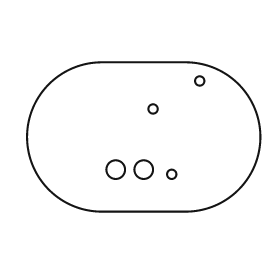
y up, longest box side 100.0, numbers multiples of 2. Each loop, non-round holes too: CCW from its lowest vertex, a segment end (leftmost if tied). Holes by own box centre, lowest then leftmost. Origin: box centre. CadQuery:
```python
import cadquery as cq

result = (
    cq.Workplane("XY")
    .moveTo(-18.0, -32.0)
    .lineTo(18.0, -32.0)
    .threePointArc((50.0, 0.0), (18.0, 32.0))
    .lineTo(-18.0, 32.0)
    .threePointArc((-50.0, 0.0), (-18.0, -32.0))
    .close()
    .moveTo(12.0, -16.0)
    .circle(2.0)
    .moveTo(-12.0, -14.0)
    .circle(4.0)
    .moveTo(0.0, -14.0)
    .circle(4.0)
    .moveTo(4.0, 12.0)
    .circle(2.0)
    .moveTo(24.0, 24.0)
    .circle(2.0)
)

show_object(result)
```